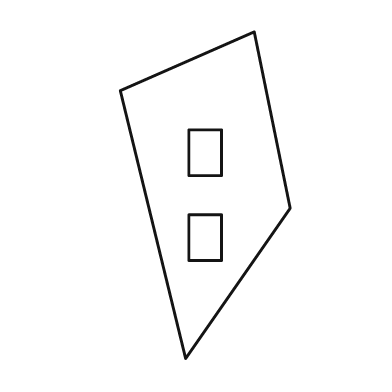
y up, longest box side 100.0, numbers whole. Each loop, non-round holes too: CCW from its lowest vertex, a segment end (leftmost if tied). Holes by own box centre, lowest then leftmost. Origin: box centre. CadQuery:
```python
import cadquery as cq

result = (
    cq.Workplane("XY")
    .moveTo(-6.0, -50.0)
    .lineTo(26.0, -4.0)
    .lineTo(15.0, 50.0)
    .lineTo(-26.0, 32.0)
    .close()
    .moveTo(-5.0, -20.0)
    .lineTo(5.0, -20.0)
    .lineTo(5.0, -6.0)
    .lineTo(-5.0, -6.0)
    .close()
    .moveTo(-5.0, 6.0)
    .lineTo(5.0, 6.0)
    .lineTo(5.0, 20.0)
    .lineTo(-5.0, 20.0)
    .close()
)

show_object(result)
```